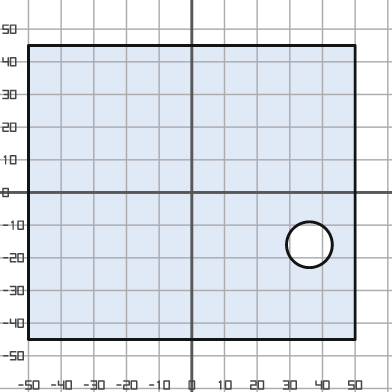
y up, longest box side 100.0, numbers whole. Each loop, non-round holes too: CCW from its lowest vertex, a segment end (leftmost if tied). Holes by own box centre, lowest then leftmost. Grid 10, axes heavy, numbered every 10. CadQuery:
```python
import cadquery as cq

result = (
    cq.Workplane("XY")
    .moveTo(-50.0, -45.0)
    .lineTo(50.0, -45.0)
    .lineTo(50.0, 45.0)
    .lineTo(-50.0, 45.0)
    .close()
    .moveTo(36.0, -16.0)
    .circle(7.0)
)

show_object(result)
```